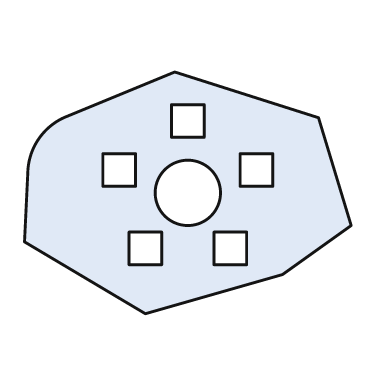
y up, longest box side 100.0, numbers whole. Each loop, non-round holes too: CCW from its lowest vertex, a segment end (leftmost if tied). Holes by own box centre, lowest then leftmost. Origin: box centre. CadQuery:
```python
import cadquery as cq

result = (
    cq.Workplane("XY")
    .moveTo(-13.0, -37.0)
    .lineTo(29.0, -25.0)
    .lineTo(50.0, -10.0)
    .lineTo(40.0, 23.0)
    .lineTo(-4.0, 37.0)
    .lineTo(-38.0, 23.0)
    .threePointArc((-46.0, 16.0), (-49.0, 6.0))
    .lineTo(-50.0, -15.0)
    .close()
    .moveTo(-18.0, -22.0)
    .lineTo(-8.0, -22.0)
    .lineTo(-8.0, -12.0)
    .lineTo(-18.0, -12.0)
    .close()
    .moveTo(8.0, -22.0)
    .lineTo(18.0, -22.0)
    .lineTo(18.0, -12.0)
    .lineTo(8.0, -12.0)
    .close()
    .moveTo(0.0, 0.0)
    .circle(10.0)
    .moveTo(-26.0, 2.0)
    .lineTo(-16.0, 2.0)
    .lineTo(-16.0, 12.0)
    .lineTo(-26.0, 12.0)
    .close()
    .moveTo(16.0, 2.0)
    .lineTo(26.0, 2.0)
    .lineTo(26.0, 12.0)
    .lineTo(16.0, 12.0)
    .close()
    .moveTo(-5.0, 17.0)
    .lineTo(5.0, 17.0)
    .lineTo(5.0, 27.0)
    .lineTo(-5.0, 27.0)
    .close()
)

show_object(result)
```